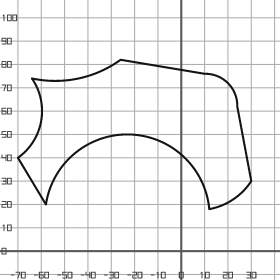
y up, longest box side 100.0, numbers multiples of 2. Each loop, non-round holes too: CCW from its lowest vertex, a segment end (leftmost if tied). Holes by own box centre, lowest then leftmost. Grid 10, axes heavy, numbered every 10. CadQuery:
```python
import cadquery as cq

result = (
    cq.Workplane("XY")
    .moveTo(12.0, 18.0)
    .threePointArc((22.0, 22.0), (30.0, 30.0))
    .lineTo(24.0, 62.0)
    .threePointArc((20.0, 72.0), (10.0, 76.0))
    .lineTo(-26.0, 82.0)
    .threePointArc((-44.0, 74.0), (-64.0, 74.0))
    .threePointArc((-60.0, 56.0), (-70.0, 40.0))
    .lineTo(-58.0, 20.0)
    .threePointArc((-22.0, 50.0), (12.0, 18.0))
    .close()
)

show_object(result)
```